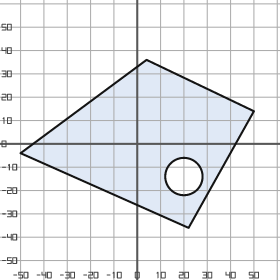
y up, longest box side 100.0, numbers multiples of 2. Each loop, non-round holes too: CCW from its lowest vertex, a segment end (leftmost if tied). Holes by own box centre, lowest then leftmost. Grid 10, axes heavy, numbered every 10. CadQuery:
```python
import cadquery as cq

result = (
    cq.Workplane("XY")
    .moveTo(22.0, -36.0)
    .lineTo(50.0, 14.0)
    .lineTo(4.0, 36.0)
    .lineTo(-50.0, -4.0)
    .close()
    .moveTo(20.0, -14.0)
    .circle(8.0)
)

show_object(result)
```